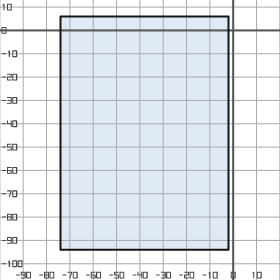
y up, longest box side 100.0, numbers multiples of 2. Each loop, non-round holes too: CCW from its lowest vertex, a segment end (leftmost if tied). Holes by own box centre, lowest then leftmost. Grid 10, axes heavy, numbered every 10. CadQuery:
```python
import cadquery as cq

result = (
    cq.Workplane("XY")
    .moveTo(-74.0, -94.0)
    .lineTo(-2.0, -94.0)
    .lineTo(-2.0, 6.0)
    .lineTo(-74.0, 6.0)
    .close()
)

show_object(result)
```